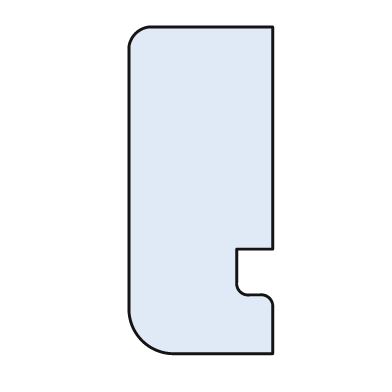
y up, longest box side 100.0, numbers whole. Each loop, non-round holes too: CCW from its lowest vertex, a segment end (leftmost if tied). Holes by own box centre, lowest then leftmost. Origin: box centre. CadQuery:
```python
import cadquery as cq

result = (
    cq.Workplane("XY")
    .moveTo(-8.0, -50.0)
    .lineTo(22.0, -50.0)
    .lineTo(22.0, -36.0)
    .threePointArc((21.0, -33.0), (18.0, -32.0))
    .lineTo(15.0, -32.0)
    .threePointArc((12.0, -31.0), (11.0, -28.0))
    .lineTo(11.0, -18.0)
    .lineTo(22.0, -18.0)
    .lineTo(22.0, 50.0)
    .lineTo(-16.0, 50.0)
    .threePointArc((-20.0, 48.0), (-22.0, 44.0))
    .lineTo(-22.0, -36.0)
    .threePointArc((-18.0, -46.0), (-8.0, -50.0))
    .close()
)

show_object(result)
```